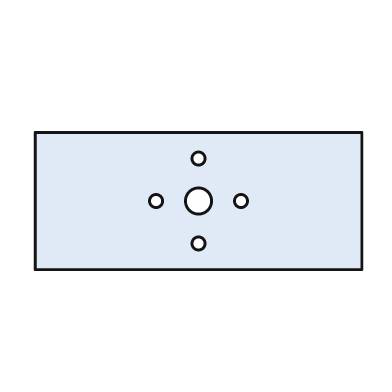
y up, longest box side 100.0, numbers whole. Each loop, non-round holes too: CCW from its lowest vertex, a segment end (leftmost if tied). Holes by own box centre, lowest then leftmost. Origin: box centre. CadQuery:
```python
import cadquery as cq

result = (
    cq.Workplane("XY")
    .moveTo(-50.0, -21.0)
    .lineTo(50.0, -21.0)
    .lineTo(50.0, 21.0)
    .lineTo(-50.0, 21.0)
    .close()
    .moveTo(0.0, -13.0)
    .circle(2.0)
    .moveTo(-13.0, 0.0)
    .circle(2.0)
    .moveTo(0.0, 0.0)
    .circle(4.0)
    .moveTo(13.0, 0.0)
    .circle(2.0)
    .moveTo(0.0, 13.0)
    .circle(2.0)
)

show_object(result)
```